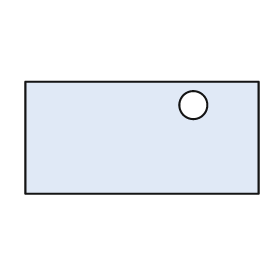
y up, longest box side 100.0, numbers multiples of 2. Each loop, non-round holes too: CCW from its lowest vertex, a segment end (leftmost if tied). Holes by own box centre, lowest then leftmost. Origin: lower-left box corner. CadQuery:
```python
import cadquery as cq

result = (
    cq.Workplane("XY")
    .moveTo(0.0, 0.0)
    .lineTo(100.0, 0.0)
    .lineTo(100.0, 48.0)
    .lineTo(0.0, 48.0)
    .close()
    .moveTo(72.0, 38.0)
    .circle(6.0)
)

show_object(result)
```